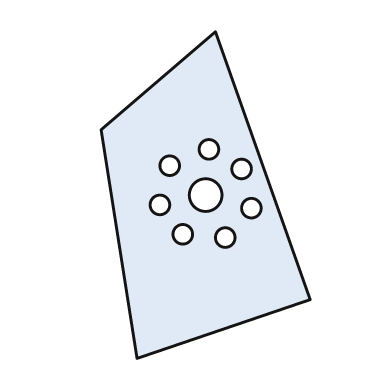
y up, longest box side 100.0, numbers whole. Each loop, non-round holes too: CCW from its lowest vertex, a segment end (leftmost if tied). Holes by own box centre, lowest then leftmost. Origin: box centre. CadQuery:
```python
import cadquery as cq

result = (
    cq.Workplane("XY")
    .moveTo(-21.0, -50.0)
    .lineTo(32.0, -32.0)
    .lineTo(3.0, 50.0)
    .lineTo(-32.0, 20.0)
    .close()
    .moveTo(6.0, -13.0)
    .circle(3.0)
    .moveTo(-7.0, -12.0)
    .circle(3.0)
    .moveTo(14.0, -4.0)
    .circle(3.0)
    .moveTo(-14.0, -3.0)
    .circle(3.0)
    .moveTo(0.0, 0.0)
    .circle(5.0)
    .moveTo(11.0, 8.0)
    .circle(3.0)
    .moveTo(-11.0, 9.0)
    .circle(3.0)
    .moveTo(1.0, 14.0)
    .circle(3.0)
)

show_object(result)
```